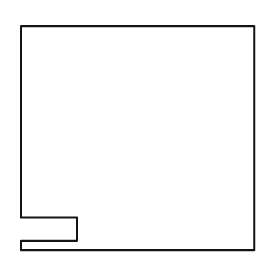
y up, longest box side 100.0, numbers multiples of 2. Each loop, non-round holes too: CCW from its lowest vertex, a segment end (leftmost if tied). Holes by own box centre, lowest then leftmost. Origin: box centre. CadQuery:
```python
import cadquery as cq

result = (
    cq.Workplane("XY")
    .moveTo(-50.0, -48.0)
    .lineTo(50.0, -48.0)
    .lineTo(50.0, 48.0)
    .lineTo(-50.0, 48.0)
    .lineTo(-50.0, -34.0)
    .lineTo(-26.0, -34.0)
    .lineTo(-26.0, -44.0)
    .lineTo(-50.0, -44.0)
    .close()
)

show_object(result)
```